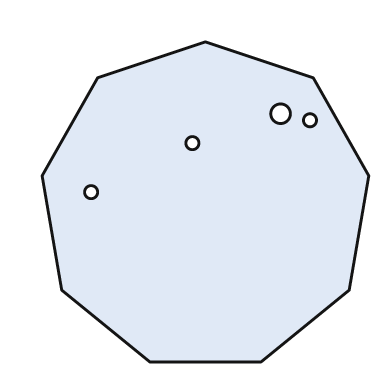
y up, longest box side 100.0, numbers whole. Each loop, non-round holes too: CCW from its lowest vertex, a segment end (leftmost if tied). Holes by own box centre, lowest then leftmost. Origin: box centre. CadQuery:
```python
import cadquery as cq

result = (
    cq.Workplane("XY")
    .moveTo(-17.0, -49.0)
    .lineTo(17.0, -49.0)
    .lineTo(44.0, -27.0)
    .lineTo(50.0, 8.0)
    .lineTo(33.0, 38.0)
    .lineTo(0.0, 49.0)
    .lineTo(-33.0, 38.0)
    .lineTo(-50.0, 8.0)
    .lineTo(-44.0, -27.0)
    .close()
    .moveTo(-35.0, 3.0)
    .circle(2.0)
    .moveTo(-4.0, 18.0)
    .circle(2.0)
    .moveTo(32.0, 25.0)
    .circle(2.0)
    .moveTo(23.0, 27.0)
    .circle(3.0)
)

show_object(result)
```